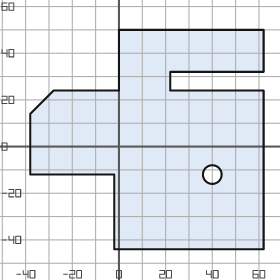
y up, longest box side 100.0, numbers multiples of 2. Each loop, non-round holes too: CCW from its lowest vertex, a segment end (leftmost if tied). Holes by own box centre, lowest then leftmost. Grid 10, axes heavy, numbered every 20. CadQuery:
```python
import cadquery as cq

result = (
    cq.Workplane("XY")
    .moveTo(-2.0, -44.0)
    .lineTo(62.0, -44.0)
    .lineTo(62.0, 24.0)
    .lineTo(22.0, 24.0)
    .lineTo(22.0, 32.0)
    .lineTo(62.0, 32.0)
    .lineTo(62.0, 50.0)
    .lineTo(0.0, 50.0)
    .lineTo(0.0, 24.0)
    .lineTo(-28.0, 24.0)
    .lineTo(-38.0, 14.0)
    .lineTo(-38.0, -12.0)
    .lineTo(-2.0, -12.0)
    .close()
    .moveTo(40.0, -12.0)
    .circle(4.0)
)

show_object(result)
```